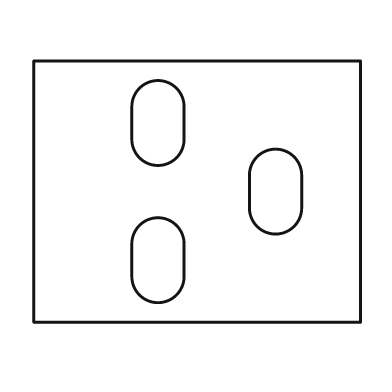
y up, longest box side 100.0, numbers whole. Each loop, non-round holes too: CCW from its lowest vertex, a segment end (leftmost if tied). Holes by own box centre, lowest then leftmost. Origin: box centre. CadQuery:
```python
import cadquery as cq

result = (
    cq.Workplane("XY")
    .moveTo(-50.0, -40.0)
    .lineTo(50.0, -40.0)
    .lineTo(50.0, 40.0)
    .lineTo(-50.0, 40.0)
    .close()
    .moveTo(-20.0, -26.0)
    .threePointArc((-12.0, -34.0), (-4.0, -26.0))
    .lineTo(-4.0, -16.0)
    .threePointArc((-12.0, -8.0), (-20.0, -16.0))
    .close()
    .moveTo(16.0, -5.0)
    .threePointArc((24.0, -13.0), (32.0, -5.0))
    .lineTo(32.0, 5.0)
    .threePointArc((24.0, 13.0), (16.0, 5.0))
    .close()
    .moveTo(-20.0, 16.0)
    .threePointArc((-12.0, 8.0), (-4.0, 16.0))
    .lineTo(-4.0, 26.0)
    .threePointArc((-12.0, 34.0), (-20.0, 26.0))
    .close()
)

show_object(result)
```